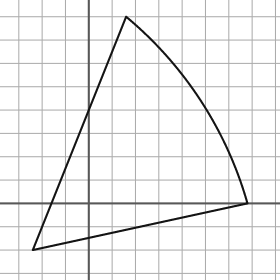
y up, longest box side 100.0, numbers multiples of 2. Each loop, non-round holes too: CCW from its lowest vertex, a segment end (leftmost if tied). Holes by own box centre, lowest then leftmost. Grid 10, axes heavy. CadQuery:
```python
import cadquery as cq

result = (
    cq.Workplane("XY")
    .moveTo(-24.0, -20.0)
    .lineTo(68.0, 0.0)
    .threePointArc((48.0, 44.0), (16.0, 80.0))
    .close()
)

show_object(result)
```